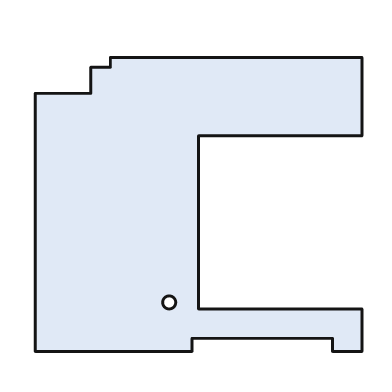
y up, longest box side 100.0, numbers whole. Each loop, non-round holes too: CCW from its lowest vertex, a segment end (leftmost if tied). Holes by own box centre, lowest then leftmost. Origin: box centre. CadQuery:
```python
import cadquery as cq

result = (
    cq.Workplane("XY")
    .moveTo(-50.0, -45.0)
    .lineTo(-2.0, -45.0)
    .lineTo(-2.0, -41.0)
    .lineTo(41.0, -41.0)
    .lineTo(41.0, -45.0)
    .lineTo(50.0, -45.0)
    .lineTo(50.0, -32.0)
    .lineTo(0.0, -32.0)
    .lineTo(0.0, 21.0)
    .lineTo(50.0, 21.0)
    .lineTo(50.0, 45.0)
    .lineTo(-27.0, 45.0)
    .lineTo(-27.0, 42.0)
    .lineTo(-33.0, 42.0)
    .lineTo(-33.0, 34.0)
    .lineTo(-50.0, 34.0)
    .close()
    .moveTo(-9.0, -30.0)
    .circle(2.0)
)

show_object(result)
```